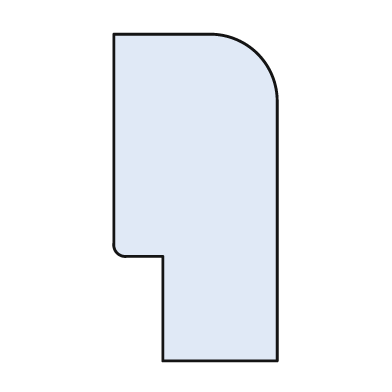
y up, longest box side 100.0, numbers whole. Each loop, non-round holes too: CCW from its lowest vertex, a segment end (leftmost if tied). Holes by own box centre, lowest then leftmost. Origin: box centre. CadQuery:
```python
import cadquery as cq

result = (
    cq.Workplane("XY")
    .moveTo(-10.0, -50.0)
    .lineTo(25.0, -50.0)
    .lineTo(25.0, 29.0)
    .threePointArc((19.0, 44.0), (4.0, 50.0))
    .lineTo(-25.0, 50.0)
    .lineTo(-25.0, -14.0)
    .threePointArc((-24.0, -17.0), (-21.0, -18.0))
    .lineTo(-10.0, -18.0)
    .close()
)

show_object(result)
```